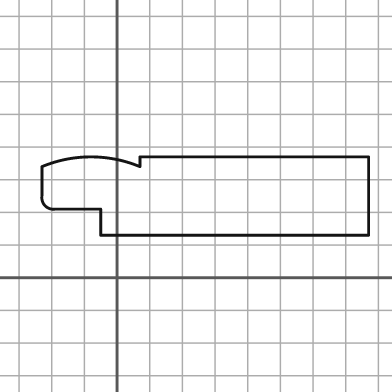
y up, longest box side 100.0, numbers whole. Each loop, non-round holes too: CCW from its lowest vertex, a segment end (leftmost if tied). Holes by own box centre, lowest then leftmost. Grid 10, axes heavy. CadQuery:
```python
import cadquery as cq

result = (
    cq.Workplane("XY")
    .moveTo(-5.0, 13.0)
    .lineTo(77.0, 13.0)
    .lineTo(77.0, 37.0)
    .lineTo(7.0, 37.0)
    .lineTo(7.0, 34.0)
    .threePointArc((-8.0, 37.0), (-23.0, 34.0))
    .lineTo(-23.0, 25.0)
    .threePointArc((-22.0, 22.0), (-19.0, 21.0))
    .lineTo(-5.0, 21.0)
    .close()
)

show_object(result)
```